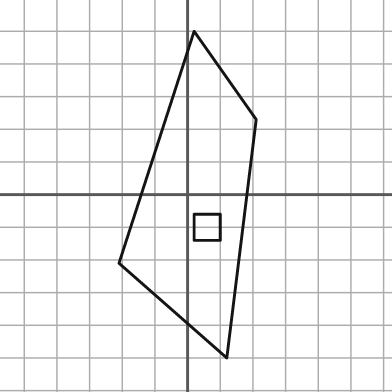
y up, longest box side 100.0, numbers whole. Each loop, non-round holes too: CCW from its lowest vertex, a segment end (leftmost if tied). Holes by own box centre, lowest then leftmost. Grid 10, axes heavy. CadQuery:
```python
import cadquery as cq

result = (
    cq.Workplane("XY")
    .moveTo(12.0, -50.0)
    .lineTo(21.0, 23.0)
    .lineTo(2.0, 50.0)
    .lineTo(-21.0, -21.0)
    .close()
    .moveTo(2.0, -14.0)
    .lineTo(10.0, -14.0)
    .lineTo(10.0, -6.0)
    .lineTo(2.0, -6.0)
    .close()
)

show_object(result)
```